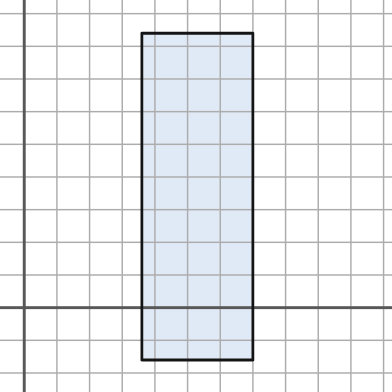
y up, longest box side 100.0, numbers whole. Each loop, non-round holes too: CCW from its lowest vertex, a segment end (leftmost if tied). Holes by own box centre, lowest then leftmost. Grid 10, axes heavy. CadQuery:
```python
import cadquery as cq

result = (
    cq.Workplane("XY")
    .moveTo(36.0, -16.0)
    .lineTo(70.0, -16.0)
    .lineTo(70.0, 84.0)
    .lineTo(36.0, 84.0)
    .close()
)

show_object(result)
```